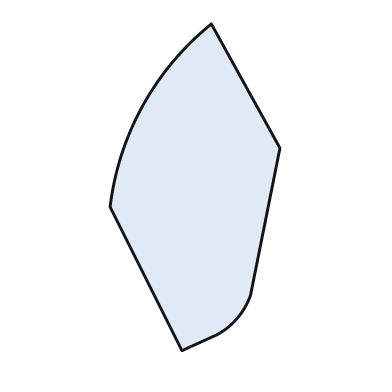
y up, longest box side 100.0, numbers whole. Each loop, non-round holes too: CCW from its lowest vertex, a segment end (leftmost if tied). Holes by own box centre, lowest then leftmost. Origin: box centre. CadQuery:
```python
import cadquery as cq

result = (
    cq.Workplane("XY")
    .moveTo(-4.0, -50.0)
    .lineTo(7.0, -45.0)
    .threePointArc((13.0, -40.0), (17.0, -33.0))
    .lineTo(26.0, 12.0)
    .lineTo(5.0, 50.0)
    .threePointArc((-16.0, 25.0), (-26.0, -6.0))
    .close()
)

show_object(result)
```